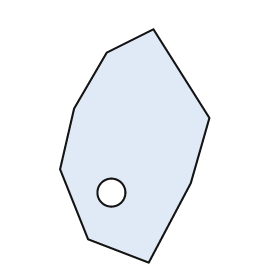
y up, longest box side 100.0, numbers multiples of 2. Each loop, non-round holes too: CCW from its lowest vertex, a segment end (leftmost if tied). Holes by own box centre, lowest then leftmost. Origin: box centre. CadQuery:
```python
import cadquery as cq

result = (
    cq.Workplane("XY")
    .moveTo(6.0, -50.0)
    .lineTo(24.0, -16.0)
    .lineTo(32.0, 12.0)
    .lineTo(8.0, 50.0)
    .lineTo(-12.0, 40.0)
    .lineTo(-26.0, 16.0)
    .lineTo(-32.0, -10.0)
    .lineTo(-20.0, -40.0)
    .close()
    .moveTo(-10.0, -20.0)
    .circle(6.0)
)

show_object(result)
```